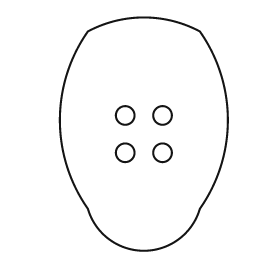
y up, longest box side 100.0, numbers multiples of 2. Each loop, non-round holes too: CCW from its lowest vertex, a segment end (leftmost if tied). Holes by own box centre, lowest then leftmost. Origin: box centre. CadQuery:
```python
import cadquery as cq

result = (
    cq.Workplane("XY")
    .moveTo(-24.0, -32.0)
    .threePointArc((0.0, -50.0), (24.0, -32.0))
    .threePointArc((36.0, 6.0), (24.0, 44.0))
    .threePointArc((0.0, 50.0), (-24.0, 44.0))
    .threePointArc((-36.0, 6.0), (-24.0, -32.0))
    .close()
    .moveTo(-8.0, -8.0)
    .circle(4.0)
    .moveTo(8.0, -8.0)
    .circle(4.0)
    .moveTo(-8.0, 8.0)
    .circle(4.0)
    .moveTo(8.0, 8.0)
    .circle(4.0)
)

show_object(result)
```